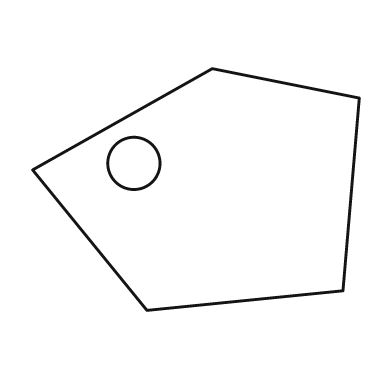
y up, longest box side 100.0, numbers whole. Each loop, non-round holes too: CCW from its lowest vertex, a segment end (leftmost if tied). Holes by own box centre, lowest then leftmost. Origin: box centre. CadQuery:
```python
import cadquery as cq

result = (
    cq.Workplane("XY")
    .moveTo(-15.0, -37.0)
    .lineTo(45.0, -31.0)
    .lineTo(50.0, 28.0)
    .lineTo(5.0, 37.0)
    .lineTo(-50.0, 6.0)
    .close()
    .moveTo(-19.0, 8.0)
    .circle(8.0)
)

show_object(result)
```